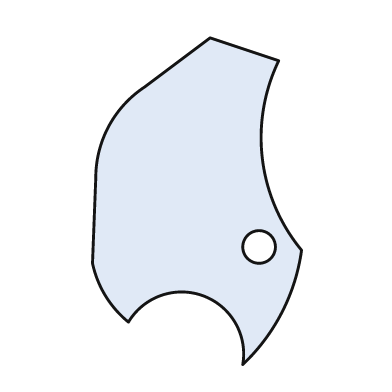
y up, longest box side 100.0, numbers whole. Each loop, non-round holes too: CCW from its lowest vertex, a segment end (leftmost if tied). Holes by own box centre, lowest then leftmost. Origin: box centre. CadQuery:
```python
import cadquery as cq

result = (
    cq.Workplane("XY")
    .moveTo(14.0, -50.0)
    .threePointArc((26.0, -34.0), (32.0, -15.0))
    .threePointArc((20.0, 13.0), (25.0, 43.0))
    .lineTo(4.0, 50.0)
    .lineTo(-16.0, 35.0)
    .threePointArc((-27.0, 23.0), (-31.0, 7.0))
    .lineTo(-32.0, -19.0)
    .threePointArc((-28.0, -29.0), (-21.0, -37.0))
    .threePointArc((2.0, -29.0), (14.0, -50.0))
    .close()
    .moveTo(19.0, -14.0)
    .circle(5.0)
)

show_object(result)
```